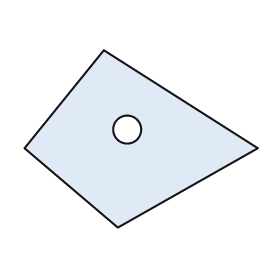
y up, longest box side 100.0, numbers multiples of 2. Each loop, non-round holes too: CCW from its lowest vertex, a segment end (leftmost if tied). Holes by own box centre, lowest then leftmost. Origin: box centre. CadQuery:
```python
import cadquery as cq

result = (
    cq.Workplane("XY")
    .moveTo(-10.0, -38.0)
    .lineTo(50.0, -4.0)
    .lineTo(-16.0, 38.0)
    .lineTo(-50.0, -4.0)
    .close()
    .moveTo(-6.0, 4.0)
    .circle(6.0)
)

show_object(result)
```